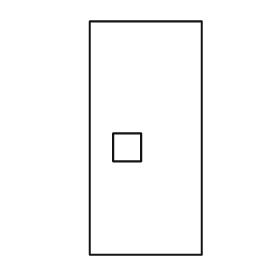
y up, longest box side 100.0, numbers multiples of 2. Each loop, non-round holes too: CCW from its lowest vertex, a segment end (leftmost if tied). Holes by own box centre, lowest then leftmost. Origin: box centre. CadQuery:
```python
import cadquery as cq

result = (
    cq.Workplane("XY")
    .moveTo(-24.0, -50.0)
    .lineTo(24.0, -50.0)
    .lineTo(24.0, 50.0)
    .lineTo(-24.0, 50.0)
    .close()
    .moveTo(-14.0, -10.0)
    .lineTo(-2.0, -10.0)
    .lineTo(-2.0, 2.0)
    .lineTo(-14.0, 2.0)
    .close()
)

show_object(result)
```